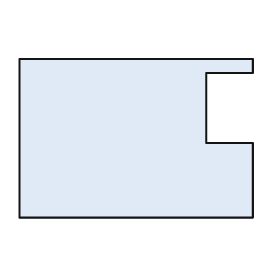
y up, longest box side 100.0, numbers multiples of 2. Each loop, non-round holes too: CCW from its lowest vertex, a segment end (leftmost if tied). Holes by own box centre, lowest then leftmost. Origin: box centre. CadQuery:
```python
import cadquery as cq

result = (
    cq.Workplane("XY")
    .moveTo(-50.0, -34.0)
    .lineTo(50.0, -34.0)
    .lineTo(50.0, -2.0)
    .lineTo(30.0, -2.0)
    .lineTo(30.0, 28.0)
    .lineTo(50.0, 28.0)
    .lineTo(50.0, 34.0)
    .lineTo(-50.0, 34.0)
    .close()
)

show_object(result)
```